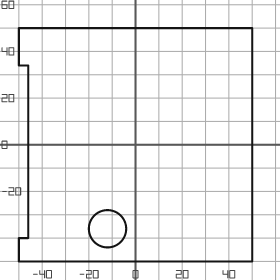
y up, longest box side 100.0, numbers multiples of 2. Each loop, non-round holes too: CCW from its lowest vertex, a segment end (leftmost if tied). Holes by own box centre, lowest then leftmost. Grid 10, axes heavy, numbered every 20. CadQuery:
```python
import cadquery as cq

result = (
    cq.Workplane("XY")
    .moveTo(-50.0, -50.0)
    .lineTo(50.0, -50.0)
    .lineTo(50.0, 50.0)
    .lineTo(-50.0, 50.0)
    .lineTo(-50.0, 34.0)
    .lineTo(-46.0, 34.0)
    .lineTo(-46.0, -40.0)
    .lineTo(-50.0, -40.0)
    .close()
    .moveTo(-12.0, -36.0)
    .circle(8.0)
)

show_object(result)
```